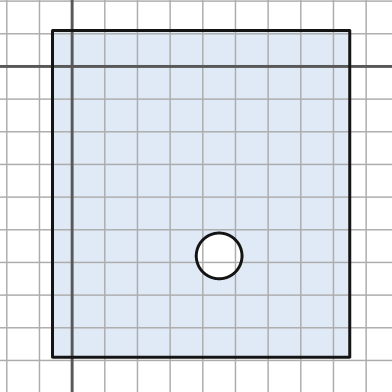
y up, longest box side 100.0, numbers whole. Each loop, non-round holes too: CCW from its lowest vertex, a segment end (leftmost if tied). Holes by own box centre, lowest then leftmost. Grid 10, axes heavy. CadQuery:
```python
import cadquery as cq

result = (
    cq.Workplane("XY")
    .moveTo(-6.0, -89.0)
    .lineTo(85.0, -89.0)
    .lineTo(85.0, 11.0)
    .lineTo(-6.0, 11.0)
    .close()
    .moveTo(45.0, -58.0)
    .circle(7.0)
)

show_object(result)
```